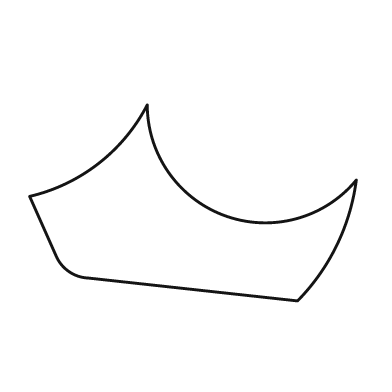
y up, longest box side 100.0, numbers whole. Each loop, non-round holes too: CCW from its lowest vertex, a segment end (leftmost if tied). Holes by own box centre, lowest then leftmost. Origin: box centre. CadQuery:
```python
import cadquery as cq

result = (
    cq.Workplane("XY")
    .moveTo(32.0, -30.0)
    .threePointArc((44.0, -13.0), (50.0, 7.0))
    .threePointArc((10.0, -4.0), (-14.0, 30.0))
    .threePointArc((-29.0, 12.0), (-50.0, 2.0))
    .lineTo(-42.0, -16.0)
    .threePointArc((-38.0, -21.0), (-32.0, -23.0))
    .close()
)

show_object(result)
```